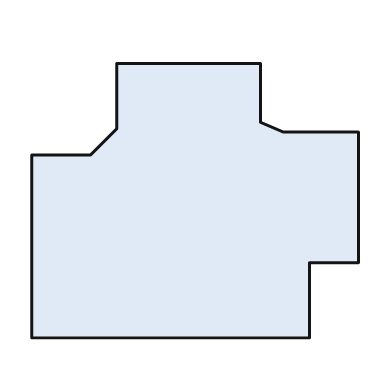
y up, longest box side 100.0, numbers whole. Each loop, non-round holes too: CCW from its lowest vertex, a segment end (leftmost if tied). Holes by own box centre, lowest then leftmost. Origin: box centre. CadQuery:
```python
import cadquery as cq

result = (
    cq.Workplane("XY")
    .moveTo(-50.0, -42.0)
    .lineTo(35.0, -42.0)
    .lineTo(35.0, -19.0)
    .lineTo(50.0, -19.0)
    .lineTo(50.0, 21.0)
    .lineTo(27.0, 21.0)
    .lineTo(20.0, 24.0)
    .lineTo(20.0, 42.0)
    .lineTo(-24.0, 42.0)
    .lineTo(-24.0, 22.0)
    .lineTo(-32.0, 14.0)
    .lineTo(-50.0, 14.0)
    .close()
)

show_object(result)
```